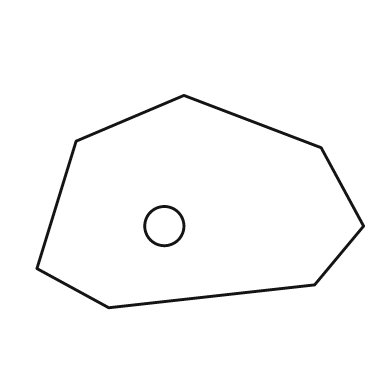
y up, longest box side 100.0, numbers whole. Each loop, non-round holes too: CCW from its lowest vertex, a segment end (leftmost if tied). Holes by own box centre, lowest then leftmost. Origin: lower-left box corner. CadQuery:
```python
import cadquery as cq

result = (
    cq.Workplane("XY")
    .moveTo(22.0, 0.0)
    .lineTo(85.0, 7.0)
    .lineTo(100.0, 25.0)
    .lineTo(87.0, 49.0)
    .lineTo(45.0, 65.0)
    .lineTo(12.0, 51.0)
    .lineTo(0.0, 12.0)
    .close()
    .moveTo(39.0, 25.0)
    .circle(6.0)
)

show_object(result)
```